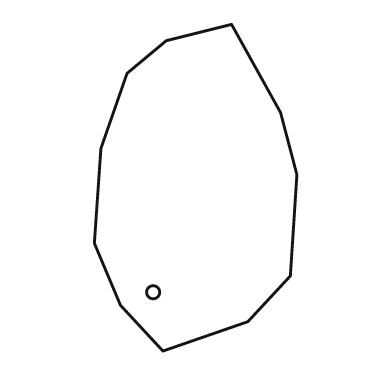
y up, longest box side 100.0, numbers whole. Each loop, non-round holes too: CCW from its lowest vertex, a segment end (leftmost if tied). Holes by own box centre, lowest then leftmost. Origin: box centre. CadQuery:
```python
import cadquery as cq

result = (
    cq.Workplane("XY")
    .moveTo(-10.0, -50.0)
    .lineTo(16.0, -41.0)
    .lineTo(29.0, -27.0)
    .lineTo(31.0, 4.0)
    .lineTo(26.0, 23.0)
    .lineTo(11.0, 50.0)
    .lineTo(-9.0, 45.0)
    .lineTo(-21.0, 35.0)
    .lineTo(-29.0, 12.0)
    .lineTo(-31.0, -17.0)
    .lineTo(-23.0, -36.0)
    .close()
    .moveTo(-13.0, -32.0)
    .circle(2.0)
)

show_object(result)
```